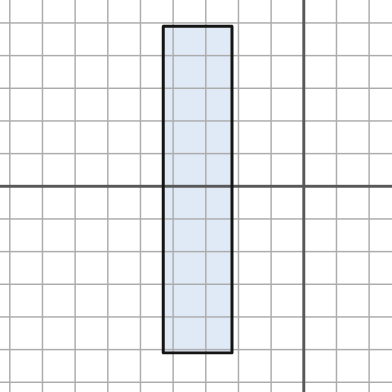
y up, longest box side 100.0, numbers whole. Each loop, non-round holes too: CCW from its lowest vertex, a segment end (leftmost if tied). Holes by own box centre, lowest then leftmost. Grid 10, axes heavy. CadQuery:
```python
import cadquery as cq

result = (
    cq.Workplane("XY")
    .moveTo(-43.0, -51.0)
    .lineTo(-22.0, -51.0)
    .lineTo(-22.0, 49.0)
    .lineTo(-43.0, 49.0)
    .close()
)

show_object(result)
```